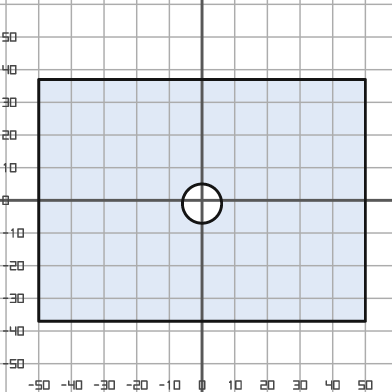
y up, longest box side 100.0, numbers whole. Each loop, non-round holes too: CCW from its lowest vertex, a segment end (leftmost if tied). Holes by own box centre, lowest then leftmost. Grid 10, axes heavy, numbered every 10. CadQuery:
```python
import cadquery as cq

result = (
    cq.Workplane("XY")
    .moveTo(-50.0, -37.0)
    .lineTo(50.0, -37.0)
    .lineTo(50.0, 37.0)
    .lineTo(-50.0, 37.0)
    .close()
    .moveTo(0.0, -1.0)
    .circle(6.0)
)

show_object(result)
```